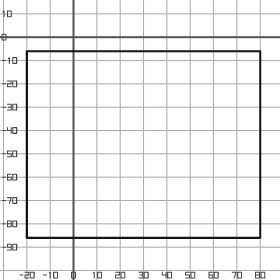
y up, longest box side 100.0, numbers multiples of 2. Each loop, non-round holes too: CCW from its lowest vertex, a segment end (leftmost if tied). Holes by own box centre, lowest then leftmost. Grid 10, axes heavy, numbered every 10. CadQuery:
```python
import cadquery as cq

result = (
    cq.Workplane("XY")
    .moveTo(-20.0, -86.0)
    .lineTo(80.0, -86.0)
    .lineTo(80.0, -6.0)
    .lineTo(-20.0, -6.0)
    .close()
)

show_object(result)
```